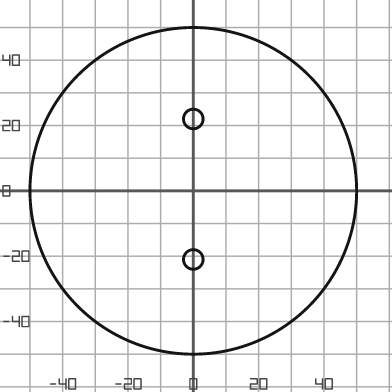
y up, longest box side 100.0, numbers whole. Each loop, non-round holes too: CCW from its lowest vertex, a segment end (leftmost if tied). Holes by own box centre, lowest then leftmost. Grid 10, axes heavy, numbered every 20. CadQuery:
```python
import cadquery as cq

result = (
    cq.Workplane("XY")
    .moveTo(0.0, 0.0)
    .circle(50.0)
    .moveTo(0.0, -21.0)
    .circle(3.0)
    .moveTo(0.0, 22.0)
    .circle(3.0)
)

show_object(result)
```